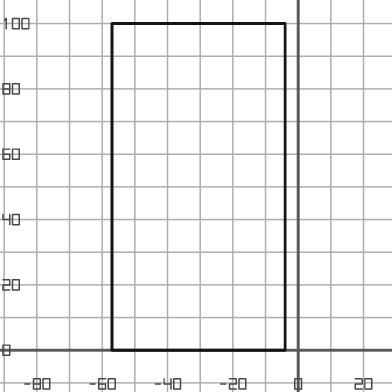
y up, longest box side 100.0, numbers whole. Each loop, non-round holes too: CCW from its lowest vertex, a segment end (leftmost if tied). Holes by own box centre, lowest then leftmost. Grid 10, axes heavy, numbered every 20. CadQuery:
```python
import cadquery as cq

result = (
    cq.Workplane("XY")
    .moveTo(-57.0, 0.0)
    .lineTo(-4.0, 0.0)
    .lineTo(-4.0, 100.0)
    .lineTo(-57.0, 100.0)
    .close()
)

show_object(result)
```